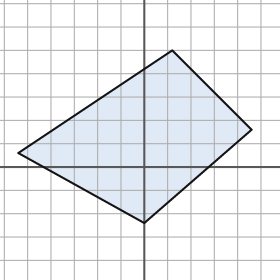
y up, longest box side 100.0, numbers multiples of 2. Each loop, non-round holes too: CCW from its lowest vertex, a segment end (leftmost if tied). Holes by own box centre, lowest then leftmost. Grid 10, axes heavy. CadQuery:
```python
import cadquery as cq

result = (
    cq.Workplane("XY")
    .moveTo(0.0, -24.0)
    .lineTo(46.0, 16.0)
    .lineTo(12.0, 50.0)
    .lineTo(-54.0, 6.0)
    .close()
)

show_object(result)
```